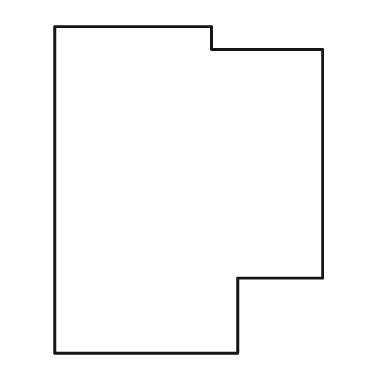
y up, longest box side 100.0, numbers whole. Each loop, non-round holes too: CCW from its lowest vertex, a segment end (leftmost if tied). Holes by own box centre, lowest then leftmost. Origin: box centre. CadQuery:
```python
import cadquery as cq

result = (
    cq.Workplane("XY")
    .moveTo(-41.0, -50.0)
    .lineTo(15.0, -50.0)
    .lineTo(15.0, -27.0)
    .lineTo(41.0, -27.0)
    .lineTo(41.0, 43.0)
    .lineTo(7.0, 43.0)
    .lineTo(7.0, 50.0)
    .lineTo(-41.0, 50.0)
    .close()
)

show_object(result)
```